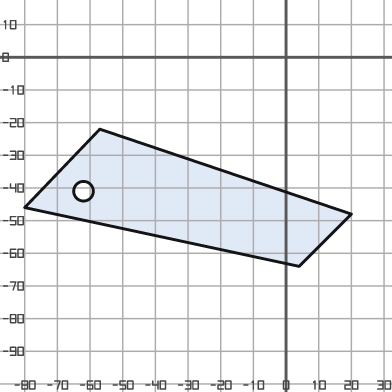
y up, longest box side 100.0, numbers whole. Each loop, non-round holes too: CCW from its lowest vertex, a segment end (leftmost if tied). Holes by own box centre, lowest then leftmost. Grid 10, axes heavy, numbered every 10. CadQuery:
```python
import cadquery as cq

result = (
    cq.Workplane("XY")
    .moveTo(4.0, -64.0)
    .lineTo(20.0, -48.0)
    .lineTo(-57.0, -22.0)
    .lineTo(-80.0, -46.0)
    .close()
    .moveTo(-62.0, -41.0)
    .circle(3.0)
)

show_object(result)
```